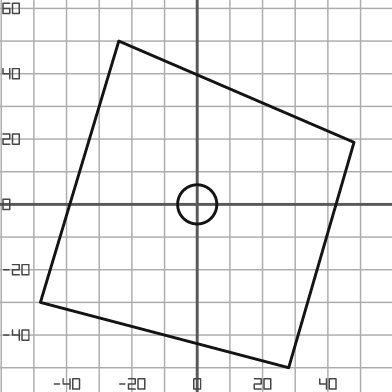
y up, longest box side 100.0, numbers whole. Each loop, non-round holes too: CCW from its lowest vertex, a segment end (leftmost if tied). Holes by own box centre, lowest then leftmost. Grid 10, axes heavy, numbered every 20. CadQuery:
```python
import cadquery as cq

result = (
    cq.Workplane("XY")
    .moveTo(28.0, -50.0)
    .lineTo(48.0, 19.0)
    .lineTo(-24.0, 50.0)
    .lineTo(-48.0, -30.0)
    .close()
    .moveTo(0.0, 0.0)
    .circle(6.0)
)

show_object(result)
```